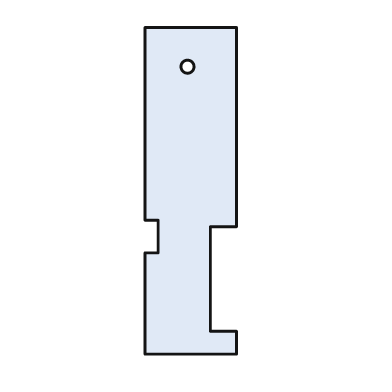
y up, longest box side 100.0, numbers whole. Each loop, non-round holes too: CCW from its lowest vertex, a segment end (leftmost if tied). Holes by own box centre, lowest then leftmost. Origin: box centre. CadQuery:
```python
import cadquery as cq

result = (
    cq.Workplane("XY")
    .moveTo(-14.0, -50.0)
    .lineTo(14.0, -50.0)
    .lineTo(14.0, -43.0)
    .lineTo(6.0, -43.0)
    .lineTo(6.0, -11.0)
    .lineTo(14.0, -11.0)
    .lineTo(14.0, 50.0)
    .lineTo(-14.0, 50.0)
    .lineTo(-14.0, -9.0)
    .lineTo(-10.0, -9.0)
    .lineTo(-10.0, -19.0)
    .lineTo(-14.0, -19.0)
    .close()
    .moveTo(-1.0, 38.0)
    .circle(2.0)
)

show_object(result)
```